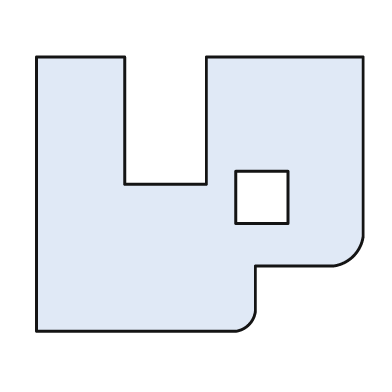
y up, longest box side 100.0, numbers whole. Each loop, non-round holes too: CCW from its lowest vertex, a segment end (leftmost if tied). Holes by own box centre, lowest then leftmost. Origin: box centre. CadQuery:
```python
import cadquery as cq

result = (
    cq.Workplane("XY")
    .moveTo(-50.0, -42.0)
    .lineTo(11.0, -42.0)
    .threePointArc((15.0, -40.0), (17.0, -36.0))
    .lineTo(17.0, -22.0)
    .lineTo(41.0, -22.0)
    .threePointArc((47.0, -19.0), (50.0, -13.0))
    .lineTo(50.0, 42.0)
    .lineTo(2.0, 42.0)
    .lineTo(2.0, 3.0)
    .lineTo(-23.0, 3.0)
    .lineTo(-23.0, 42.0)
    .lineTo(-50.0, 42.0)
    .close()
    .moveTo(11.0, -9.0)
    .lineTo(27.0, -9.0)
    .lineTo(27.0, 7.0)
    .lineTo(11.0, 7.0)
    .close()
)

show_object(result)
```